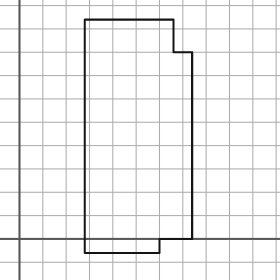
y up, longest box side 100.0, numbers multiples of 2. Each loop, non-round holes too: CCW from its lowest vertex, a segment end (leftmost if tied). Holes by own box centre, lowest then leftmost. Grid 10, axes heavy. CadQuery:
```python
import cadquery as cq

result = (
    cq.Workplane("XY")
    .moveTo(28.0, -6.0)
    .lineTo(60.0, -6.0)
    .lineTo(60.0, 0.0)
    .lineTo(74.0, 0.0)
    .lineTo(74.0, 80.0)
    .lineTo(66.0, 80.0)
    .lineTo(66.0, 94.0)
    .lineTo(28.0, 94.0)
    .close()
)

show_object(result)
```